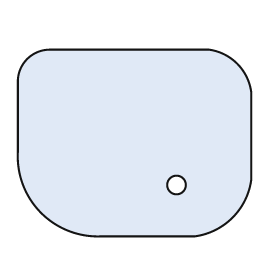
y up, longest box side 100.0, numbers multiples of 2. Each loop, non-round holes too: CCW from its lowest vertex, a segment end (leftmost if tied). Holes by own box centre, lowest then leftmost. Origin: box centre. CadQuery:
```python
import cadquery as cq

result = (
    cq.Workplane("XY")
    .moveTo(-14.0, -40.0)
    .lineTo(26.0, -40.0)
    .threePointArc((42.0, -32.0), (50.0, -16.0))
    .lineTo(50.0, 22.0)
    .threePointArc((44.0, 34.0), (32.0, 40.0))
    .lineTo(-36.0, 40.0)
    .threePointArc((-46.0, 36.0), (-50.0, 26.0))
    .lineTo(-50.0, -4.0)
    .threePointArc((-40.0, -30.0), (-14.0, -40.0))
    .close()
    .moveTo(18.0, -18.0)
    .circle(4.0)
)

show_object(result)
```